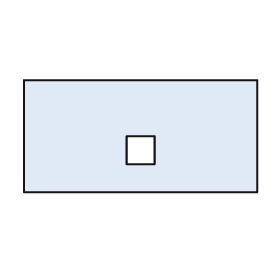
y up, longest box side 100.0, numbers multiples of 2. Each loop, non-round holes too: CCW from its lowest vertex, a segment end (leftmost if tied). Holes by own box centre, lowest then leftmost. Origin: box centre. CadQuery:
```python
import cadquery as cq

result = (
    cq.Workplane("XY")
    .moveTo(-50.0, -24.0)
    .lineTo(50.0, -24.0)
    .lineTo(50.0, 24.0)
    .lineTo(-50.0, 24.0)
    .close()
    .moveTo(-6.0, -12.0)
    .lineTo(6.0, -12.0)
    .lineTo(6.0, 0.0)
    .lineTo(-6.0, 0.0)
    .close()
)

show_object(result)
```